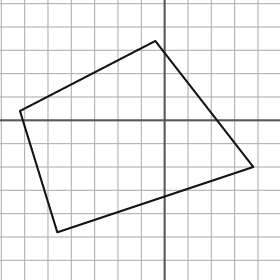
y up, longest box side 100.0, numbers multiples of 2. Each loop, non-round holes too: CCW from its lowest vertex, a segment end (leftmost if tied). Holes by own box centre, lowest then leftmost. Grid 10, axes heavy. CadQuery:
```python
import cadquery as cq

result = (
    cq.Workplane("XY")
    .moveTo(-46.0, -48.0)
    .lineTo(38.0, -20.0)
    .lineTo(-4.0, 34.0)
    .lineTo(-62.0, 4.0)
    .close()
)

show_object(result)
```